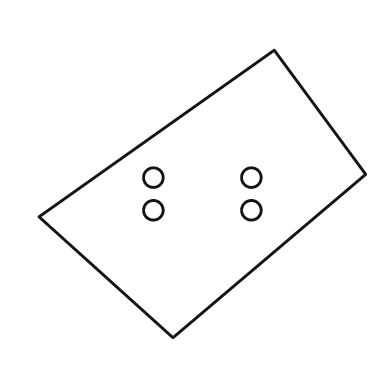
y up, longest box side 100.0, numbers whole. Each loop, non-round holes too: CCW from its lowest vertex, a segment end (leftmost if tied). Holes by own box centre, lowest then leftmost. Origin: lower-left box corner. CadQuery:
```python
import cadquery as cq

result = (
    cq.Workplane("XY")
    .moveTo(41.0, 0.0)
    .lineTo(100.0, 50.0)
    .lineTo(72.0, 88.0)
    .lineTo(0.0, 37.0)
    .close()
    .moveTo(35.0, 39.0)
    .circle(3.0)
    .moveTo(65.0, 39.0)
    .circle(3.0)
    .moveTo(35.0, 49.0)
    .circle(3.0)
    .moveTo(65.0, 49.0)
    .circle(3.0)
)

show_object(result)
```